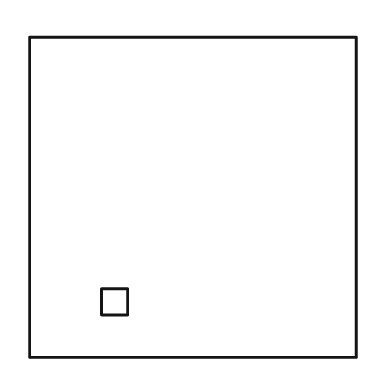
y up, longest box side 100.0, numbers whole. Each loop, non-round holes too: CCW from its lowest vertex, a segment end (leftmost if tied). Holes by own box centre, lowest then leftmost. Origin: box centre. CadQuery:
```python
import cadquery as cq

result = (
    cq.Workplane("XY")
    .moveTo(-50.0, -49.0)
    .lineTo(50.0, -49.0)
    .lineTo(50.0, 49.0)
    .lineTo(-50.0, 49.0)
    .close()
    .moveTo(-28.0, -36.0)
    .lineTo(-20.0, -36.0)
    .lineTo(-20.0, -28.0)
    .lineTo(-28.0, -28.0)
    .close()
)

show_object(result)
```